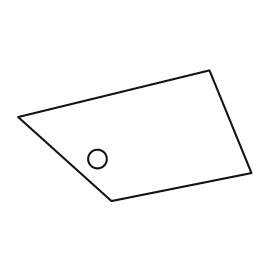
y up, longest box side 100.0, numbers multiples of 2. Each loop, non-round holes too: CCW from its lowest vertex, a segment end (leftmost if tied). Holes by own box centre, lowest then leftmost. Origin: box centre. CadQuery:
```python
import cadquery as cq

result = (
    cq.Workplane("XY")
    .moveTo(-10.0, -28.0)
    .lineTo(50.0, -16.0)
    .lineTo(32.0, 28.0)
    .lineTo(-50.0, 8.0)
    .close()
    .moveTo(-16.0, -10.0)
    .circle(4.0)
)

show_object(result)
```